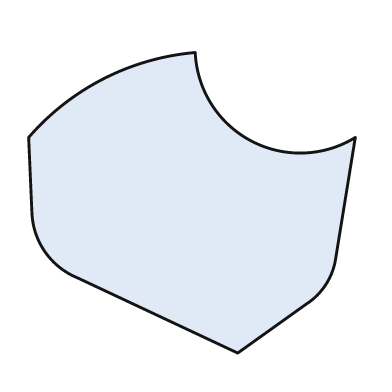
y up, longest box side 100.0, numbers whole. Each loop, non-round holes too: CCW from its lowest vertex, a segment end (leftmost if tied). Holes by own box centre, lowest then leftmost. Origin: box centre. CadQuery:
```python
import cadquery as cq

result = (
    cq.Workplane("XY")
    .moveTo(14.0, -46.0)
    .lineTo(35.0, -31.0)
    .threePointArc((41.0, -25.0), (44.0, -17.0))
    .lineTo(50.0, 20.0)
    .threePointArc((18.0, 19.0), (1.0, 46.0))
    .threePointArc((-27.0, 38.0), (-50.0, 20.0))
    .lineTo(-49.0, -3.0)
    .threePointArc((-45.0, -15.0), (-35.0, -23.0))
    .close()
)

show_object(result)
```